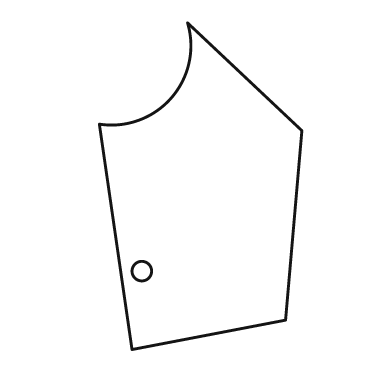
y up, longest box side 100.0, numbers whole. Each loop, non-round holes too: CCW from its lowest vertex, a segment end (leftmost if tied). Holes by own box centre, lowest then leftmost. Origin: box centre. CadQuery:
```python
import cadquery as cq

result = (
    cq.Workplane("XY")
    .moveTo(-21.0, -50.0)
    .lineTo(26.0, -41.0)
    .lineTo(31.0, 17.0)
    .lineTo(-4.0, 50.0)
    .threePointArc((-9.0, 27.0), (-31.0, 19.0))
    .close()
    .moveTo(-18.0, -26.0)
    .circle(3.0)
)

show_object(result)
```